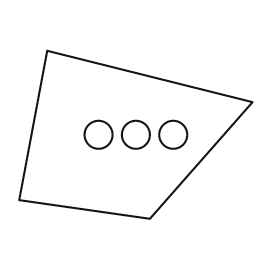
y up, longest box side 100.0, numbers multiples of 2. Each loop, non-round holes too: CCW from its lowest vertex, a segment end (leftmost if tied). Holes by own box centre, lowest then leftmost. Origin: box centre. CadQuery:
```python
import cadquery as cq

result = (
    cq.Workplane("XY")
    .moveTo(6.0, -36.0)
    .lineTo(50.0, 14.0)
    .lineTo(-38.0, 36.0)
    .lineTo(-50.0, -28.0)
    .close()
    .moveTo(-16.0, 0.0)
    .circle(6.0)
    .moveTo(0.0, 0.0)
    .circle(6.0)
    .moveTo(16.0, 0.0)
    .circle(6.0)
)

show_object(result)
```